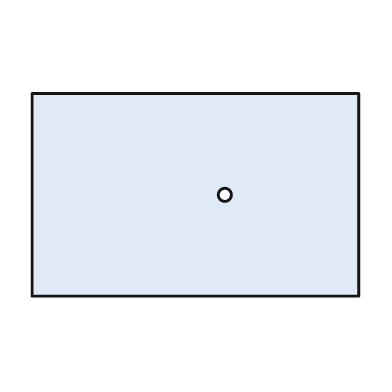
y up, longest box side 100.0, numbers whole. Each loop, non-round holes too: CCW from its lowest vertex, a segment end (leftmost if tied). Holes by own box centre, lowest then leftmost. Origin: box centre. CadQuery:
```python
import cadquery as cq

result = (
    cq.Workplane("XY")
    .moveTo(-50.0, -31.0)
    .lineTo(50.0, -31.0)
    .lineTo(50.0, 31.0)
    .lineTo(-50.0, 31.0)
    .close()
    .moveTo(9.0, 0.0)
    .circle(2.0)
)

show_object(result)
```